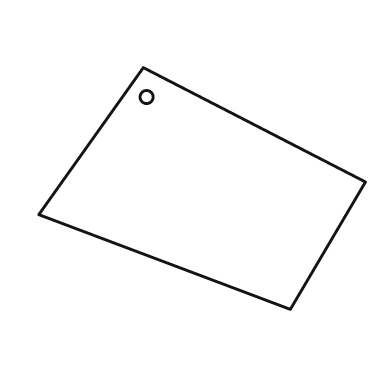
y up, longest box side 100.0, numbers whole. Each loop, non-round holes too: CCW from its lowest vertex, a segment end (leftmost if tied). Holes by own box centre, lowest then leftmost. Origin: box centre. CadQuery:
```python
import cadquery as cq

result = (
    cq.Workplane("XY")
    .moveTo(27.0, -37.0)
    .lineTo(50.0, 2.0)
    .lineTo(-18.0, 37.0)
    .lineTo(-50.0, -8.0)
    .close()
    .moveTo(-17.0, 28.0)
    .circle(2.0)
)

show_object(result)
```